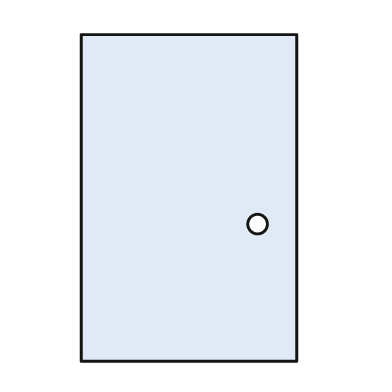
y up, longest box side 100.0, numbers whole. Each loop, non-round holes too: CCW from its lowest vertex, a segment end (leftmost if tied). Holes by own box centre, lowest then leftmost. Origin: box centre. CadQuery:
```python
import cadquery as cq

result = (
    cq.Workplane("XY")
    .moveTo(-33.0, -50.0)
    .lineTo(33.0, -50.0)
    .lineTo(33.0, 50.0)
    .lineTo(-33.0, 50.0)
    .close()
    .moveTo(21.0, -8.0)
    .circle(3.0)
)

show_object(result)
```